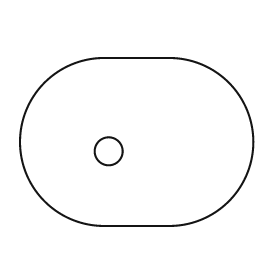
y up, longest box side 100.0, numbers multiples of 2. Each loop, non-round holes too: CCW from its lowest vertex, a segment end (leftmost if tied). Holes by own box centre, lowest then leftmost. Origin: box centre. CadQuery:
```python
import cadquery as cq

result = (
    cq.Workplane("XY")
    .moveTo(-14.0, -36.0)
    .lineTo(14.0, -36.0)
    .threePointArc((50.0, 0.0), (14.0, 36.0))
    .lineTo(-14.0, 36.0)
    .threePointArc((-50.0, 0.0), (-14.0, -36.0))
    .close()
    .moveTo(-12.0, -4.0)
    .circle(6.0)
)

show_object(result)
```